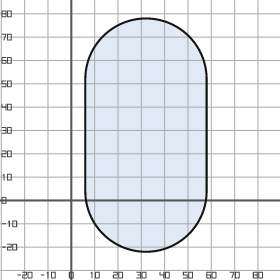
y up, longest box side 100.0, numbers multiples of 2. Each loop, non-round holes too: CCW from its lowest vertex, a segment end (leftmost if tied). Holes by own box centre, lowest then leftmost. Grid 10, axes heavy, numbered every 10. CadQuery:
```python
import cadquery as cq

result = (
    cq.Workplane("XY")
    .moveTo(6.0, 4.0)
    .threePointArc((32.0, -22.0), (58.0, 4.0))
    .lineTo(58.0, 52.0)
    .threePointArc((32.0, 78.0), (6.0, 52.0))
    .close()
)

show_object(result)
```